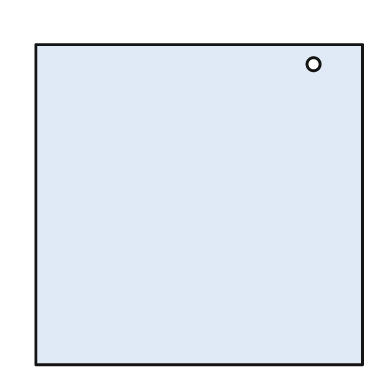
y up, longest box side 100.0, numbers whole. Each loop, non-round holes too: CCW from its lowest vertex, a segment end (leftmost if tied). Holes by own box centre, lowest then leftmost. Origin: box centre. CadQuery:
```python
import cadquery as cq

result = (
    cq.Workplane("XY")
    .moveTo(-50.0, -49.0)
    .lineTo(50.0, -49.0)
    .lineTo(50.0, 49.0)
    .lineTo(-50.0, 49.0)
    .close()
    .moveTo(35.0, 43.0)
    .circle(2.0)
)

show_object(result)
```